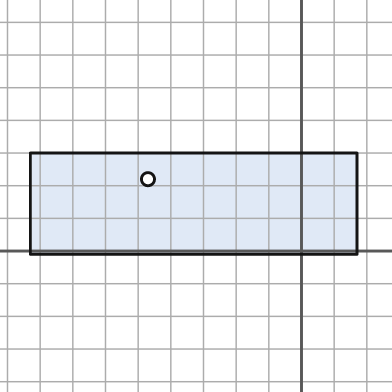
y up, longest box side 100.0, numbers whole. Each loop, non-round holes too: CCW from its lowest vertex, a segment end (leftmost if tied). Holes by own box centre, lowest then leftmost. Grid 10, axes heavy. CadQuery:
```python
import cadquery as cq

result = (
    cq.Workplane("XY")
    .moveTo(-83.0, -1.0)
    .lineTo(17.0, -1.0)
    .lineTo(17.0, 30.0)
    .lineTo(-83.0, 30.0)
    .close()
    .moveTo(-47.0, 22.0)
    .circle(2.0)
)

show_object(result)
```